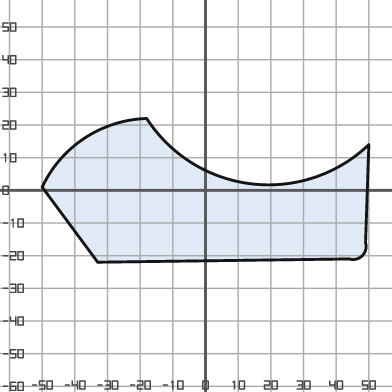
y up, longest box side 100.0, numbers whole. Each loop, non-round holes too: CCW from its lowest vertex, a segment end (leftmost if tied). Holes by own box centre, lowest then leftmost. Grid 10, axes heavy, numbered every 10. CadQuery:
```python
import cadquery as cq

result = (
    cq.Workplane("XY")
    .moveTo(-33.0, -22.0)
    .lineTo(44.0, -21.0)
    .threePointArc((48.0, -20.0), (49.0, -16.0))
    .lineTo(50.0, 14.0)
    .threePointArc((14.0, 2.0), (-18.0, 22.0))
    .threePointArc((-37.0, 16.0), (-50.0, 1.0))
    .close()
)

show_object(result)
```